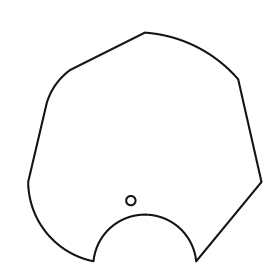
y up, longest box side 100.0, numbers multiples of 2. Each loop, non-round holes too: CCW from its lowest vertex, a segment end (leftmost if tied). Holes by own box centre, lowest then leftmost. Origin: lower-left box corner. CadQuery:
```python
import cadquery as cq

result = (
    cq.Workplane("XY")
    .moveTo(28.0, 0.0)
    .threePointArc((50.0, 20.0), (72.0, 0.0))
    .lineTo(100.0, 34.0)
    .lineTo(90.0, 78.0)
    .threePointArc((72.0, 92.0), (50.0, 98.0))
    .lineTo(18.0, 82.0)
    .threePointArc((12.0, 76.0), (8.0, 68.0))
    .lineTo(0.0, 34.0)
    .threePointArc((8.0, 12.0), (28.0, 0.0))
    .close()
    .moveTo(44.0, 26.0)
    .circle(2.0)
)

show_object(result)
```